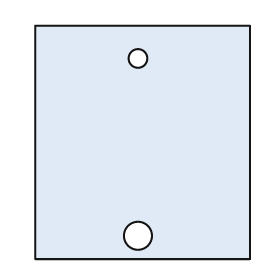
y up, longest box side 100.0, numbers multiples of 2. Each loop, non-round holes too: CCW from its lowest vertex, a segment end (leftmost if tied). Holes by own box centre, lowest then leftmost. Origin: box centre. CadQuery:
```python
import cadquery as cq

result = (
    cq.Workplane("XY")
    .moveTo(-46.0, -50.0)
    .lineTo(46.0, -50.0)
    .lineTo(46.0, 50.0)
    .lineTo(-46.0, 50.0)
    .close()
    .moveTo(-2.0, -40.0)
    .circle(6.0)
    .moveTo(-2.0, 36.0)
    .circle(4.0)
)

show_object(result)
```